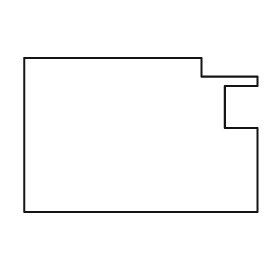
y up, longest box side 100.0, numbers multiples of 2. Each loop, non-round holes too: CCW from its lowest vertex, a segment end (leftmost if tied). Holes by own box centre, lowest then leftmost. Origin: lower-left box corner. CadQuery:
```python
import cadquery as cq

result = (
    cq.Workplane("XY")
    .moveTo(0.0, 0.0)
    .lineTo(100.0, 0.0)
    .lineTo(100.0, 36.0)
    .lineTo(86.0, 36.0)
    .lineTo(86.0, 54.0)
    .lineTo(100.0, 54.0)
    .lineTo(100.0, 58.0)
    .lineTo(76.0, 58.0)
    .lineTo(76.0, 66.0)
    .lineTo(0.0, 66.0)
    .close()
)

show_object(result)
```